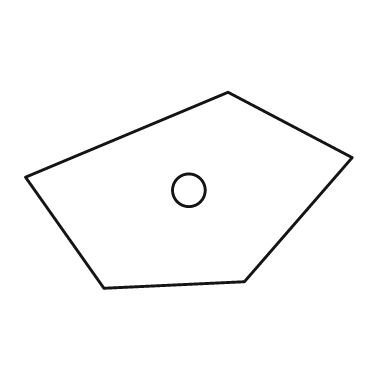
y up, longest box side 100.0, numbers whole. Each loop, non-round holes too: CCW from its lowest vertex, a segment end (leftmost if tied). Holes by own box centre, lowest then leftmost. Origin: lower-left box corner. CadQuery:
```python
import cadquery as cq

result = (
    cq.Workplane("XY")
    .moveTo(24.0, 0.0)
    .lineTo(67.0, 2.0)
    .lineTo(100.0, 40.0)
    .lineTo(62.0, 60.0)
    .lineTo(0.0, 34.0)
    .close()
    .moveTo(50.0, 30.0)
    .circle(5.0)
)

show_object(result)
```